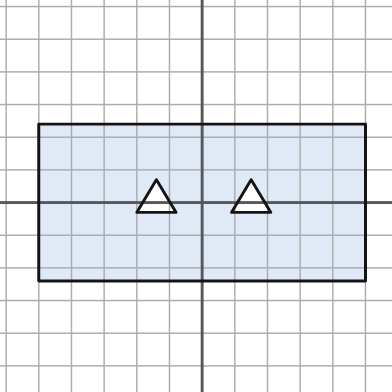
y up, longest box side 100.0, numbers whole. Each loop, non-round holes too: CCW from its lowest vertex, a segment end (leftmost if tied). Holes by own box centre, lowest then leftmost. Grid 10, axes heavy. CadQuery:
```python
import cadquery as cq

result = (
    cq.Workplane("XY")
    .moveTo(-50.0, -24.0)
    .lineTo(50.0, -24.0)
    .lineTo(50.0, 24.0)
    .lineTo(-50.0, 24.0)
    .close()
    .moveTo(-20.0, -3.0)
    .lineTo(-8.0, -3.0)
    .lineTo(-14.0, 7.0)
    .close()
    .moveTo(9.0, -3.0)
    .lineTo(21.0, -3.0)
    .lineTo(15.0, 7.0)
    .close()
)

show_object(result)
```